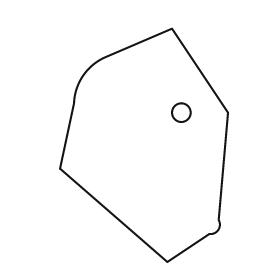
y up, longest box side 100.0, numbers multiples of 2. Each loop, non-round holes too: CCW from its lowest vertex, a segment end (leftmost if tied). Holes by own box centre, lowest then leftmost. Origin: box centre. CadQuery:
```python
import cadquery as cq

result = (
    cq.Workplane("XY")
    .moveTo(10.0, -50.0)
    .lineTo(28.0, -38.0)
    .threePointArc((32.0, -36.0), (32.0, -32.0))
    .lineTo(36.0, 14.0)
    .lineTo(12.0, 50.0)
    .lineTo(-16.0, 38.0)
    .threePointArc((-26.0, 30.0), (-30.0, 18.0))
    .lineTo(-36.0, -10.0)
    .close()
    .moveTo(16.0, 14.0)
    .circle(4.0)
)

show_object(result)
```